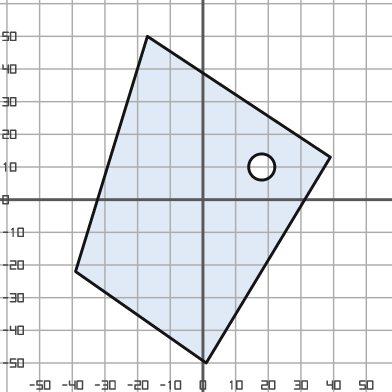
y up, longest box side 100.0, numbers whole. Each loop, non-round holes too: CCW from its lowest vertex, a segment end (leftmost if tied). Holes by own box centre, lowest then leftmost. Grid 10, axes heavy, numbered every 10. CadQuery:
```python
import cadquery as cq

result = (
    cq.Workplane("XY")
    .moveTo(1.0, -50.0)
    .lineTo(39.0, 13.0)
    .lineTo(-17.0, 50.0)
    .lineTo(-39.0, -22.0)
    .close()
    .moveTo(18.0, 10.0)
    .circle(4.0)
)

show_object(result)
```